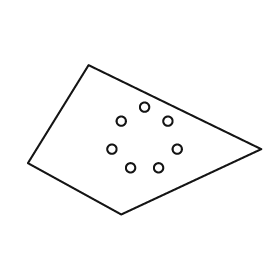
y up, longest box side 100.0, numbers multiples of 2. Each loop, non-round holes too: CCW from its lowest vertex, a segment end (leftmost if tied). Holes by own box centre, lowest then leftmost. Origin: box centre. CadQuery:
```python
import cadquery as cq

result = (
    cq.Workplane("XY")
    .moveTo(-10.0, -32.0)
    .lineTo(50.0, -4.0)
    .lineTo(-24.0, 32.0)
    .lineTo(-50.0, -10.0)
    .close()
    .moveTo(-6.0, -12.0)
    .circle(2.0)
    .moveTo(6.0, -12.0)
    .circle(2.0)
    .moveTo(-14.0, -4.0)
    .circle(2.0)
    .moveTo(14.0, -4.0)
    .circle(2.0)
    .moveTo(-10.0, 8.0)
    .circle(2.0)
    .moveTo(10.0, 8.0)
    .circle(2.0)
    .moveTo(0.0, 14.0)
    .circle(2.0)
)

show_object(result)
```